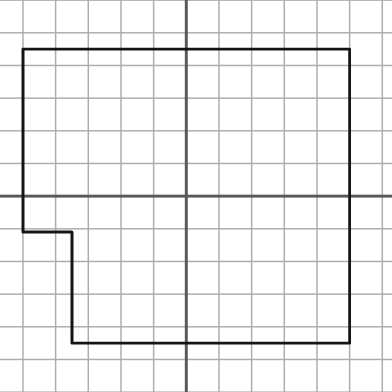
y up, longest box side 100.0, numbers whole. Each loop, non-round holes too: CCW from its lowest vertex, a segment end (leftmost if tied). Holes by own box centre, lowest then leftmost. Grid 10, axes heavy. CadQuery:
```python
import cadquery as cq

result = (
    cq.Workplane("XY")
    .moveTo(-35.0, -45.0)
    .lineTo(50.0, -45.0)
    .lineTo(50.0, 45.0)
    .lineTo(-50.0, 45.0)
    .lineTo(-50.0, -11.0)
    .lineTo(-35.0, -11.0)
    .close()
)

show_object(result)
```